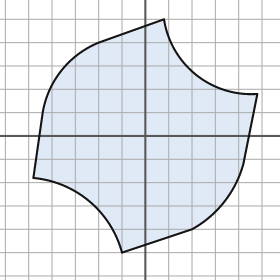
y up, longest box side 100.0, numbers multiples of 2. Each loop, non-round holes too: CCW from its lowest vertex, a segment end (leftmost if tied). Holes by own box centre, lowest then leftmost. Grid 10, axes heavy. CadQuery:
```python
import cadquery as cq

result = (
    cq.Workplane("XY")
    .moveTo(-10.0, -50.0)
    .lineTo(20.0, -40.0)
    .threePointArc((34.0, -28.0), (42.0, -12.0))
    .lineTo(48.0, 18.0)
    .threePointArc((22.0, 26.0), (8.0, 50.0))
    .lineTo(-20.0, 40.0)
    .threePointArc((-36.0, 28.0), (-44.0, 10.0))
    .lineTo(-48.0, -18.0)
    .threePointArc((-24.0, -28.0), (-10.0, -50.0))
    .close()
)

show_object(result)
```